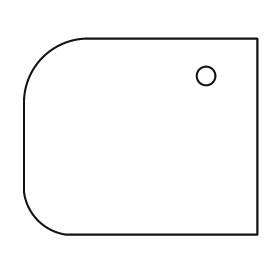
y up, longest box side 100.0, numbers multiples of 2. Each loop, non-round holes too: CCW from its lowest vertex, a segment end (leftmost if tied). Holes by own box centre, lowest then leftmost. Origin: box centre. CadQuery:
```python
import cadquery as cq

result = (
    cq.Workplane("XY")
    .moveTo(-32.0, -42.0)
    .lineTo(50.0, -42.0)
    .lineTo(50.0, 42.0)
    .lineTo(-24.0, 42.0)
    .threePointArc((-42.0, 34.0), (-50.0, 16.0))
    .lineTo(-50.0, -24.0)
    .threePointArc((-44.0, -36.0), (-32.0, -42.0))
    .close()
    .moveTo(28.0, 26.0)
    .circle(4.0)
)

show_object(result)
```